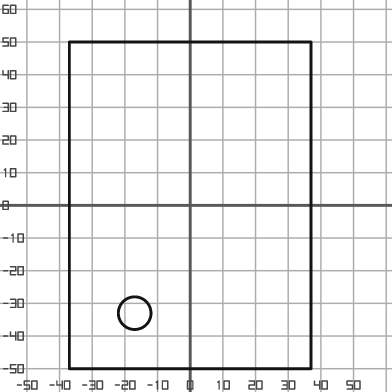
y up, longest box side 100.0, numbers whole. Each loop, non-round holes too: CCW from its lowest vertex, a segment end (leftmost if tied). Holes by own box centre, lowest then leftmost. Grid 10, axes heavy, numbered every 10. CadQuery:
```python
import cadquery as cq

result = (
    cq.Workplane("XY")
    .moveTo(-37.0, -50.0)
    .lineTo(37.0, -50.0)
    .lineTo(37.0, 50.0)
    .lineTo(-37.0, 50.0)
    .close()
    .moveTo(-17.0, -33.0)
    .circle(5.0)
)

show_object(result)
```